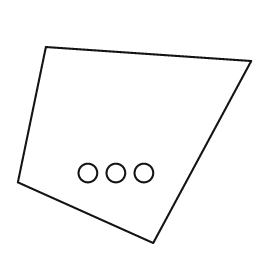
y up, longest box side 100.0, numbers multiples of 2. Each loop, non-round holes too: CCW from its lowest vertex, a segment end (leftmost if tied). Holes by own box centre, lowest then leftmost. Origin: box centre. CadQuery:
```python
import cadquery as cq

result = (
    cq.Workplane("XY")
    .moveTo(8.0, -42.0)
    .lineTo(50.0, 36.0)
    .lineTo(-38.0, 42.0)
    .lineTo(-50.0, -16.0)
    .close()
    .moveTo(-20.0, -12.0)
    .circle(4.0)
    .moveTo(-8.0, -12.0)
    .circle(4.0)
    .moveTo(4.0, -12.0)
    .circle(4.0)
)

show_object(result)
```